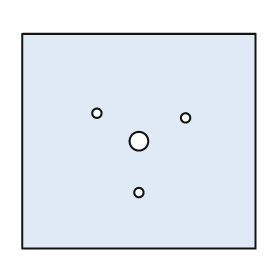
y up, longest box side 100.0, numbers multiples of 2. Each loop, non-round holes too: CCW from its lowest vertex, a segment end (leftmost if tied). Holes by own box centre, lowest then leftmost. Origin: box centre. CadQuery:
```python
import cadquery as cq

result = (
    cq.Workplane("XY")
    .moveTo(-50.0, -46.0)
    .lineTo(50.0, -46.0)
    .lineTo(50.0, 46.0)
    .lineTo(-50.0, 46.0)
    .close()
    .moveTo(0.0, -22.0)
    .circle(2.0)
    .moveTo(0.0, 0.0)
    .circle(4.0)
    .moveTo(20.0, 10.0)
    .circle(2.0)
    .moveTo(-18.0, 12.0)
    .circle(2.0)
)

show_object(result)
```